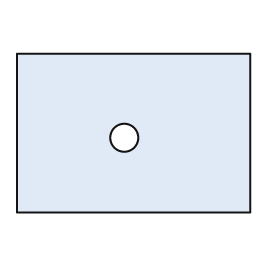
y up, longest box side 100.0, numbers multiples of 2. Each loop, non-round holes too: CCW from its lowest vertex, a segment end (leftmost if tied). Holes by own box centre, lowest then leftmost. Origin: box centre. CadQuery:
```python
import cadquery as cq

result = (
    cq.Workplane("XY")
    .moveTo(-50.0, -34.0)
    .lineTo(50.0, -34.0)
    .lineTo(50.0, 34.0)
    .lineTo(-50.0, 34.0)
    .close()
    .moveTo(-4.0, -2.0)
    .circle(6.0)
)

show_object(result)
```